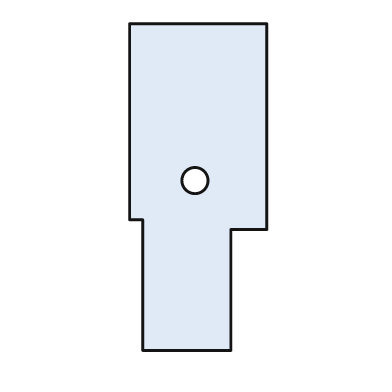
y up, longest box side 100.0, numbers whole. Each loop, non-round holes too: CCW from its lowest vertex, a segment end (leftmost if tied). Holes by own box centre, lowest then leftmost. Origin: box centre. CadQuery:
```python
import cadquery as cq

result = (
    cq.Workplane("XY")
    .moveTo(-17.0, -50.0)
    .lineTo(10.0, -50.0)
    .lineTo(10.0, -13.0)
    .lineTo(21.0, -13.0)
    .lineTo(21.0, 50.0)
    .lineTo(-21.0, 50.0)
    .lineTo(-21.0, -10.0)
    .lineTo(-17.0, -10.0)
    .close()
    .moveTo(-1.0, 2.0)
    .circle(4.0)
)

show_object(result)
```